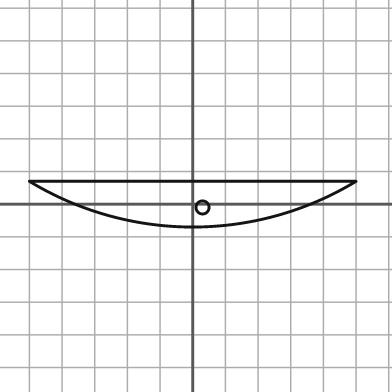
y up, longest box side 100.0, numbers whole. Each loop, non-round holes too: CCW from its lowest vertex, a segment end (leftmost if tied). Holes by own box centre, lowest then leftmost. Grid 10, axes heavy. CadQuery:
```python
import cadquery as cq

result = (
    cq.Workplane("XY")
    .moveTo(-50.0, 7.0)
    .threePointArc((0.0, -7.0), (50.0, 7.0))
    .close()
    .moveTo(3.0, -1.0)
    .circle(2.0)
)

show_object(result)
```